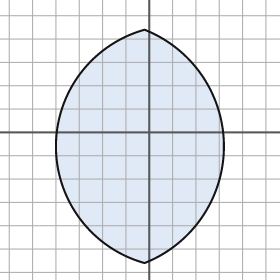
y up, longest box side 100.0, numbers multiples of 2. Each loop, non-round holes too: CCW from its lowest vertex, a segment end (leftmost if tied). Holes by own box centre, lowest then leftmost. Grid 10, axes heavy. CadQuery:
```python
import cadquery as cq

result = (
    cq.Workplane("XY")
    .moveTo(-2.0, -56.0)
    .threePointArc((32.0, -6.0), (-2.0, 44.0))
    .threePointArc((-40.0, -6.0), (-2.0, -56.0))
    .close()
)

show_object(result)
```